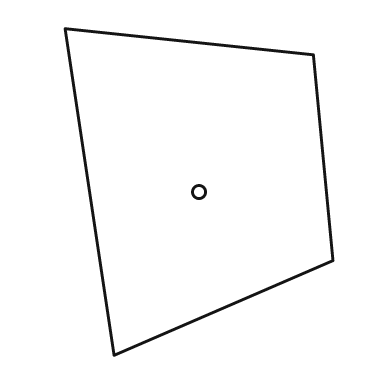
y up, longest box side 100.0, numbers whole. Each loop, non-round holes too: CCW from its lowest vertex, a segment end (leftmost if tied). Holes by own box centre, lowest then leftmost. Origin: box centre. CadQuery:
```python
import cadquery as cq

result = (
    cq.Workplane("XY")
    .moveTo(-26.0, -50.0)
    .lineTo(41.0, -21.0)
    .lineTo(35.0, 42.0)
    .lineTo(-41.0, 50.0)
    .close()
    .moveTo(0.0, 0.0)
    .circle(2.0)
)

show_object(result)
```